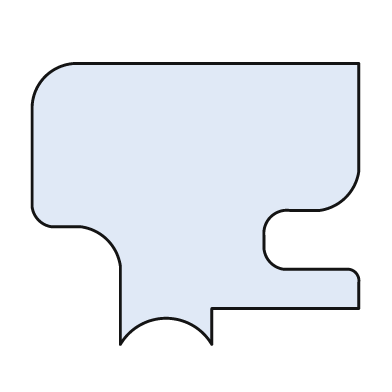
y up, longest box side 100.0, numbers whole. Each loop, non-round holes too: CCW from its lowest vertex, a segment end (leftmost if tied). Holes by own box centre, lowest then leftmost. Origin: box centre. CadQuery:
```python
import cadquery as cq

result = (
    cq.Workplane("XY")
    .moveTo(-23.0, -43.0)
    .threePointArc((-9.0, -35.0), (5.0, -43.0))
    .lineTo(5.0, -32.0)
    .lineTo(50.0, -32.0)
    .lineTo(50.0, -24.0)
    .threePointArc((49.0, -21.0), (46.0, -20.0))
    .lineTo(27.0, -20.0)
    .threePointArc((23.0, -18.0), (21.0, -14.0))
    .lineTo(21.0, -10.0)
    .threePointArc((23.0, -4.0), (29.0, -2.0))
    .lineTo(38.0, -2.0)
    .threePointArc((46.0, 2.0), (50.0, 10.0))
    .lineTo(50.0, 43.0)
    .lineTo(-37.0, 43.0)
    .threePointArc((-46.0, 39.0), (-50.0, 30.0))
    .lineTo(-50.0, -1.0)
    .threePointArc((-48.0, -5.0), (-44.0, -7.0))
    .lineTo(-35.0, -7.0)
    .threePointArc((-27.0, -11.0), (-23.0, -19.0))
    .close()
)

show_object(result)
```